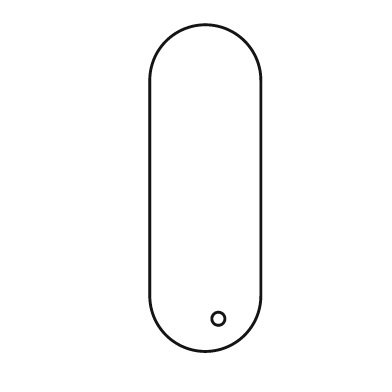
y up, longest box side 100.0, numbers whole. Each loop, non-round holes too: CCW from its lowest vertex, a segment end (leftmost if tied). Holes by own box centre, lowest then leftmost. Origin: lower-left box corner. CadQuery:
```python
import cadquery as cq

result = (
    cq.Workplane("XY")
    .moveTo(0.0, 17.0)
    .threePointArc((17.0, 0.0), (34.0, 17.0))
    .lineTo(34.0, 83.0)
    .threePointArc((17.0, 100.0), (0.0, 83.0))
    .close()
    .moveTo(21.0, 10.0)
    .circle(2.0)
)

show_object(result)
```